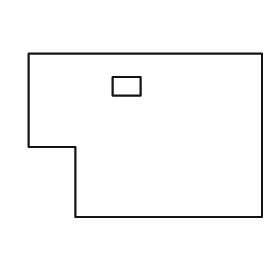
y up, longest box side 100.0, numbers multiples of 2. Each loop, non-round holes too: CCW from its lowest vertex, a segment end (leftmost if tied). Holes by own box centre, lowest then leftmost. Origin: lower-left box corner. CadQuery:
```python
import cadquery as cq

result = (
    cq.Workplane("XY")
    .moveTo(20.0, 0.0)
    .lineTo(100.0, 0.0)
    .lineTo(100.0, 70.0)
    .lineTo(0.0, 70.0)
    .lineTo(0.0, 30.0)
    .lineTo(20.0, 30.0)
    .close()
    .moveTo(36.0, 52.0)
    .lineTo(48.0, 52.0)
    .lineTo(48.0, 60.0)
    .lineTo(36.0, 60.0)
    .close()
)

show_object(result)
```